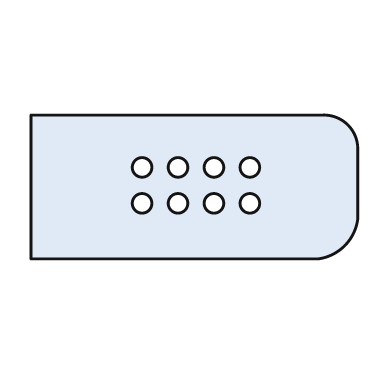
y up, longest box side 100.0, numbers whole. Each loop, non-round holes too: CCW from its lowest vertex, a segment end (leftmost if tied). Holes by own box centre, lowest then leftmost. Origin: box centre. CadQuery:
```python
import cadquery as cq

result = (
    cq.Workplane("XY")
    .moveTo(-50.0, -22.0)
    .lineTo(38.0, -22.0)
    .threePointArc((46.0, -18.0), (50.0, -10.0))
    .lineTo(50.0, 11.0)
    .threePointArc((47.0, 19.0), (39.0, 22.0))
    .lineTo(-50.0, 22.0)
    .close()
    .moveTo(-16.0, -5.0)
    .circle(3.0)
    .moveTo(-5.0, -5.0)
    .circle(3.0)
    .moveTo(6.0, -5.0)
    .circle(3.0)
    .moveTo(17.0, -5.0)
    .circle(3.0)
    .moveTo(-16.0, 6.0)
    .circle(3.0)
    .moveTo(-5.0, 6.0)
    .circle(3.0)
    .moveTo(6.0, 6.0)
    .circle(3.0)
    .moveTo(17.0, 6.0)
    .circle(3.0)
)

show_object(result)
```